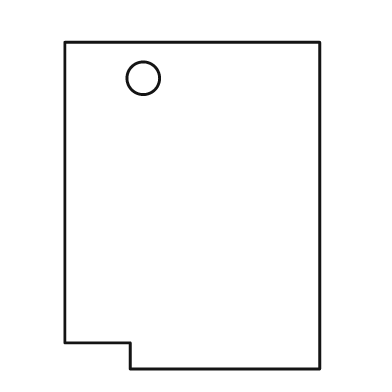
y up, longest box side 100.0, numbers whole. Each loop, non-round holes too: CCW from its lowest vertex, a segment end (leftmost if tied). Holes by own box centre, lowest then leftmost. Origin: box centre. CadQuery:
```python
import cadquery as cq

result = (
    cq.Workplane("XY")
    .moveTo(-19.0, -50.0)
    .lineTo(39.0, -50.0)
    .lineTo(39.0, 50.0)
    .lineTo(-39.0, 50.0)
    .lineTo(-39.0, -42.0)
    .lineTo(-19.0, -42.0)
    .close()
    .moveTo(-15.0, 39.0)
    .circle(5.0)
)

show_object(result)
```